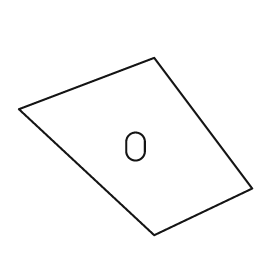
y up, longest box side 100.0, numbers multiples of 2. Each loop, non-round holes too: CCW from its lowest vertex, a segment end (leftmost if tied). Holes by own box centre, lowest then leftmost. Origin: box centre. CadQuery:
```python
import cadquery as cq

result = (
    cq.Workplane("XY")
    .moveTo(8.0, -38.0)
    .lineTo(50.0, -18.0)
    .lineTo(8.0, 38.0)
    .lineTo(-50.0, 16.0)
    .close()
    .moveTo(-4.0, -2.0)
    .threePointArc((0.0, -6.0), (4.0, -2.0))
    .lineTo(4.0, 2.0)
    .threePointArc((0.0, 6.0), (-4.0, 2.0))
    .close()
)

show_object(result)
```